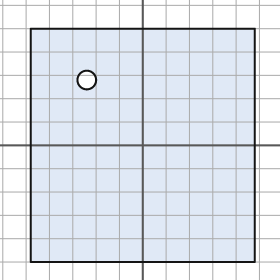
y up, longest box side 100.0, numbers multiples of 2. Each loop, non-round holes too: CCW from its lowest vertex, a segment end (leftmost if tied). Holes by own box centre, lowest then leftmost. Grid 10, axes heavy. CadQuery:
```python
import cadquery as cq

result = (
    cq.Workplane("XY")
    .moveTo(-48.0, -50.0)
    .lineTo(48.0, -50.0)
    .lineTo(48.0, 50.0)
    .lineTo(-48.0, 50.0)
    .close()
    .moveTo(-24.0, 28.0)
    .circle(4.0)
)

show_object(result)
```